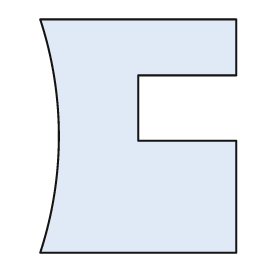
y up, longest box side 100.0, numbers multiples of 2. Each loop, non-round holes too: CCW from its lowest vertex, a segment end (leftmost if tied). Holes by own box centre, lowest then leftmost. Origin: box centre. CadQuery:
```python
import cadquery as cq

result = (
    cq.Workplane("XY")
    .moveTo(-42.0, -50.0)
    .lineTo(42.0, -50.0)
    .lineTo(42.0, -2.0)
    .lineTo(0.0, -2.0)
    .lineTo(0.0, 26.0)
    .lineTo(42.0, 26.0)
    .lineTo(42.0, 50.0)
    .lineTo(-42.0, 50.0)
    .threePointArc((-34.0, 0.0), (-42.0, -50.0))
    .close()
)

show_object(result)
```